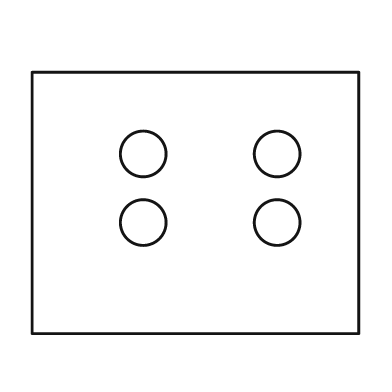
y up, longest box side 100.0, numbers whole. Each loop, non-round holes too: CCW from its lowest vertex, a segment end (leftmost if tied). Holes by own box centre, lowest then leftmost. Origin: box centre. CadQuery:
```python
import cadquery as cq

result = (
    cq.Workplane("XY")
    .moveTo(-50.0, -40.0)
    .lineTo(50.0, -40.0)
    .lineTo(50.0, 40.0)
    .lineTo(-50.0, 40.0)
    .close()
    .moveTo(-16.0, -6.0)
    .circle(7.0)
    .moveTo(25.0, -6.0)
    .circle(7.0)
    .moveTo(-16.0, 15.0)
    .circle(7.0)
    .moveTo(25.0, 15.0)
    .circle(7.0)
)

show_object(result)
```